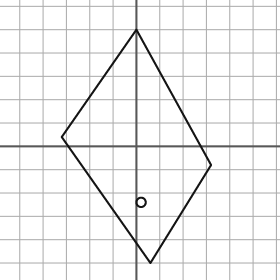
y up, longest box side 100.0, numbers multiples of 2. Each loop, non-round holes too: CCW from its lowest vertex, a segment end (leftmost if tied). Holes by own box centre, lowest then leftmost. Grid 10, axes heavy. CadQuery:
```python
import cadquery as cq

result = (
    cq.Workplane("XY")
    .moveTo(6.0, -50.0)
    .lineTo(32.0, -8.0)
    .lineTo(0.0, 50.0)
    .lineTo(-32.0, 4.0)
    .close()
    .moveTo(2.0, -24.0)
    .circle(2.0)
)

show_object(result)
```